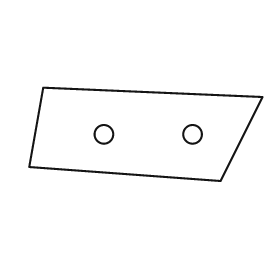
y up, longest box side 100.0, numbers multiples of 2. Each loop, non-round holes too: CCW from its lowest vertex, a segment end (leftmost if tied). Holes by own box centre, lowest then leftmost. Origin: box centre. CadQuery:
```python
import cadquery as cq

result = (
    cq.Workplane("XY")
    .moveTo(32.0, -20.0)
    .lineTo(50.0, 16.0)
    .lineTo(-44.0, 20.0)
    .lineTo(-50.0, -14.0)
    .close()
    .moveTo(-18.0, 0.0)
    .circle(4.0)
    .moveTo(20.0, 0.0)
    .circle(4.0)
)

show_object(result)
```